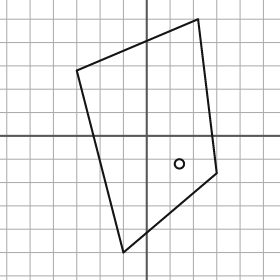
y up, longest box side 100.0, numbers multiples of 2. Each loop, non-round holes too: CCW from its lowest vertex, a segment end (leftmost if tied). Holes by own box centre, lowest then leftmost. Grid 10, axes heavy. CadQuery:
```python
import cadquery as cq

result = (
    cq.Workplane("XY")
    .moveTo(-10.0, -50.0)
    .lineTo(30.0, -16.0)
    .lineTo(22.0, 50.0)
    .lineTo(-30.0, 28.0)
    .close()
    .moveTo(14.0, -12.0)
    .circle(2.0)
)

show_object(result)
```